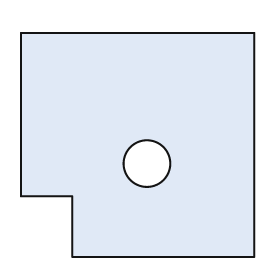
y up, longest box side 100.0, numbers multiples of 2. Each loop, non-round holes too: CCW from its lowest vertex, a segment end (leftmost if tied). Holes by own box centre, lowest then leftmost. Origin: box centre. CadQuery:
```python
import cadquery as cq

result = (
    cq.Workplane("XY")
    .moveTo(-28.0, -48.0)
    .lineTo(50.0, -48.0)
    .lineTo(50.0, 48.0)
    .lineTo(-50.0, 48.0)
    .lineTo(-50.0, -22.0)
    .lineTo(-28.0, -22.0)
    .close()
    .moveTo(4.0, -8.0)
    .circle(10.0)
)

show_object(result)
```